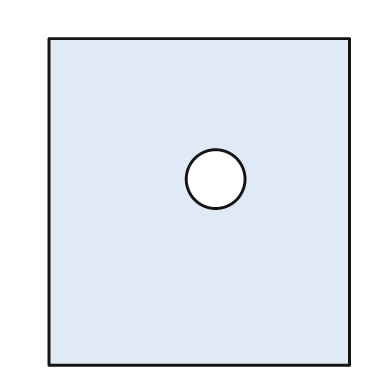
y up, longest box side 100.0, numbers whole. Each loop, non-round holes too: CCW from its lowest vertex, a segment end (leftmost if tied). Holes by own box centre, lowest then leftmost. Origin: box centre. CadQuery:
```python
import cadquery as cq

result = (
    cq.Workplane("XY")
    .moveTo(-46.0, -50.0)
    .lineTo(46.0, -50.0)
    .lineTo(46.0, 50.0)
    .lineTo(-46.0, 50.0)
    .close()
    .moveTo(5.0, 7.0)
    .circle(9.0)
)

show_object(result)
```